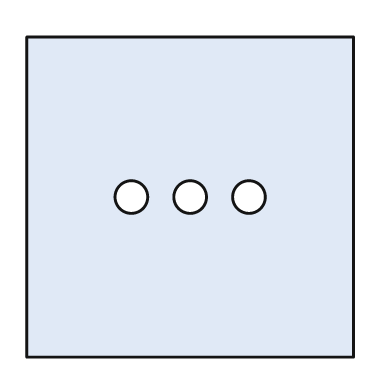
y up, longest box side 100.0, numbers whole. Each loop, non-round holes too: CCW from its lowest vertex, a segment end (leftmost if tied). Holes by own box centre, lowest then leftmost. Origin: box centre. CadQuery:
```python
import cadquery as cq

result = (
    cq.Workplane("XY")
    .moveTo(-50.0, -49.0)
    .lineTo(50.0, -49.0)
    .lineTo(50.0, 49.0)
    .lineTo(-50.0, 49.0)
    .close()
    .moveTo(-18.0, 0.0)
    .circle(5.0)
    .moveTo(0.0, 0.0)
    .circle(5.0)
    .moveTo(18.0, 0.0)
    .circle(5.0)
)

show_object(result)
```